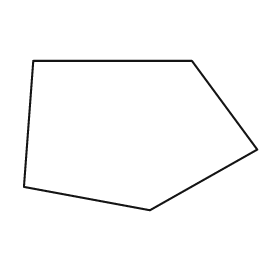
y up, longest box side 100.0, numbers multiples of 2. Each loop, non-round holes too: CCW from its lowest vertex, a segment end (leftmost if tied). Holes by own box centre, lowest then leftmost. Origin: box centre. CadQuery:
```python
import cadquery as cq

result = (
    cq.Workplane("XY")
    .moveTo(4.0, -32.0)
    .lineTo(50.0, -6.0)
    .lineTo(22.0, 32.0)
    .lineTo(-46.0, 32.0)
    .lineTo(-50.0, -22.0)
    .close()
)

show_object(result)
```